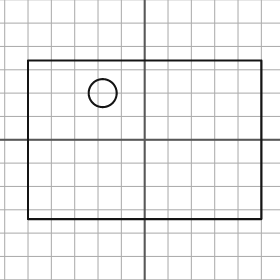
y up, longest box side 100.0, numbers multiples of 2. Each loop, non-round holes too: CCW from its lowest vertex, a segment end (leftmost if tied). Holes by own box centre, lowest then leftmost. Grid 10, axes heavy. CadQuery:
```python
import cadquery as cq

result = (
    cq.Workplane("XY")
    .moveTo(-50.0, -34.0)
    .lineTo(50.0, -34.0)
    .lineTo(50.0, 34.0)
    .lineTo(-50.0, 34.0)
    .close()
    .moveTo(-18.0, 20.0)
    .circle(6.0)
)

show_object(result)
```